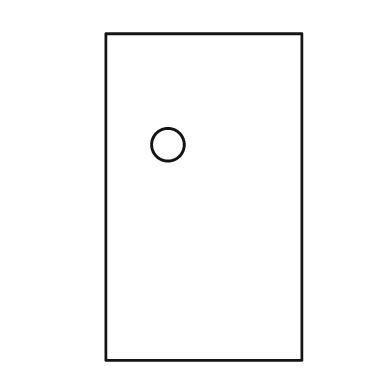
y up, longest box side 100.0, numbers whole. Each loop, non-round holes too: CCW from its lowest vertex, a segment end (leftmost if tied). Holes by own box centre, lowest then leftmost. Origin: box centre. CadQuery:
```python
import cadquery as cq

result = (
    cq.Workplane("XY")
    .moveTo(-30.0, -50.0)
    .lineTo(30.0, -50.0)
    .lineTo(30.0, 50.0)
    .lineTo(-30.0, 50.0)
    .close()
    .moveTo(-11.0, 16.0)
    .circle(5.0)
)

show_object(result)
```